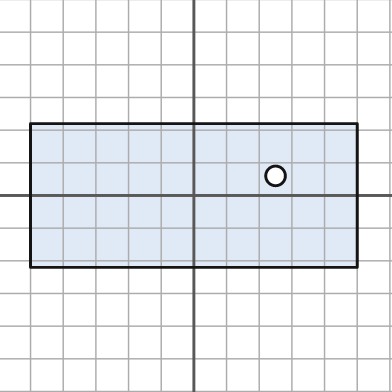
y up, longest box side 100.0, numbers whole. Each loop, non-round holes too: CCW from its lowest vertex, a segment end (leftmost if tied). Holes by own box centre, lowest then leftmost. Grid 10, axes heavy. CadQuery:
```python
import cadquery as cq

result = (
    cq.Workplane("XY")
    .moveTo(-50.0, -22.0)
    .lineTo(50.0, -22.0)
    .lineTo(50.0, 22.0)
    .lineTo(-50.0, 22.0)
    .close()
    .moveTo(25.0, 6.0)
    .circle(3.0)
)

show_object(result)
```